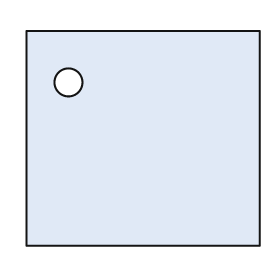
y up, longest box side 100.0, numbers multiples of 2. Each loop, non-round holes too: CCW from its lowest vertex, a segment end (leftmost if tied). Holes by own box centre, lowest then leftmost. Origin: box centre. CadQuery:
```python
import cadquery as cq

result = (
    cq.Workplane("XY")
    .moveTo(-50.0, -46.0)
    .lineTo(50.0, -46.0)
    .lineTo(50.0, 46.0)
    .lineTo(-50.0, 46.0)
    .close()
    .moveTo(-32.0, 24.0)
    .circle(6.0)
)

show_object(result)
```